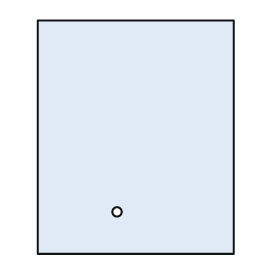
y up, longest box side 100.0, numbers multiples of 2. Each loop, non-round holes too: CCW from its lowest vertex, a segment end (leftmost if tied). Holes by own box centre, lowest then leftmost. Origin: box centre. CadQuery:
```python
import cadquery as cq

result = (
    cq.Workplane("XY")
    .moveTo(-42.0, -50.0)
    .lineTo(42.0, -50.0)
    .lineTo(42.0, 50.0)
    .lineTo(-42.0, 50.0)
    .close()
    .moveTo(-8.0, -32.0)
    .circle(2.0)
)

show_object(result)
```